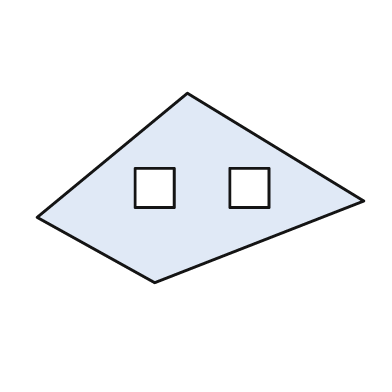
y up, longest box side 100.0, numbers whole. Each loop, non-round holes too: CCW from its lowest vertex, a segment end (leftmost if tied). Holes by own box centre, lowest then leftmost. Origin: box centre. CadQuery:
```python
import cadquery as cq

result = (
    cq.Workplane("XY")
    .moveTo(-14.0, -29.0)
    .lineTo(50.0, -4.0)
    .lineTo(-4.0, 29.0)
    .lineTo(-50.0, -9.0)
    .close()
    .moveTo(-20.0, -6.0)
    .lineTo(-8.0, -6.0)
    .lineTo(-8.0, 6.0)
    .lineTo(-20.0, 6.0)
    .close()
    .moveTo(9.0, -6.0)
    .lineTo(21.0, -6.0)
    .lineTo(21.0, 6.0)
    .lineTo(9.0, 6.0)
    .close()
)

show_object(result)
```